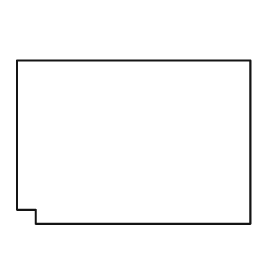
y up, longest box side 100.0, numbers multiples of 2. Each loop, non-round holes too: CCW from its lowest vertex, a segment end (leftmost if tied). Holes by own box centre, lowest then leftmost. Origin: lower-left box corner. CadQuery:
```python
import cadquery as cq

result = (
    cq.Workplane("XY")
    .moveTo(8.0, 0.0)
    .lineTo(100.0, 0.0)
    .lineTo(100.0, 70.0)
    .lineTo(0.0, 70.0)
    .lineTo(0.0, 6.0)
    .lineTo(8.0, 6.0)
    .close()
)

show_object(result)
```